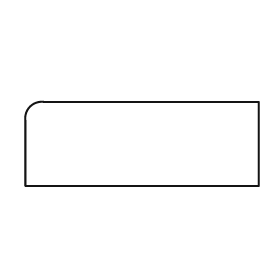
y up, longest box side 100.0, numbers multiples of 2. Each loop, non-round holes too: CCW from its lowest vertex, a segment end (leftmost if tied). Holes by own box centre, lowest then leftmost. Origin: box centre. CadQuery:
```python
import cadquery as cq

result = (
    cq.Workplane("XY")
    .moveTo(-50.0, -18.0)
    .lineTo(50.0, -18.0)
    .lineTo(50.0, 18.0)
    .lineTo(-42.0, 18.0)
    .threePointArc((-48.0, 16.0), (-50.0, 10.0))
    .close()
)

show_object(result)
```